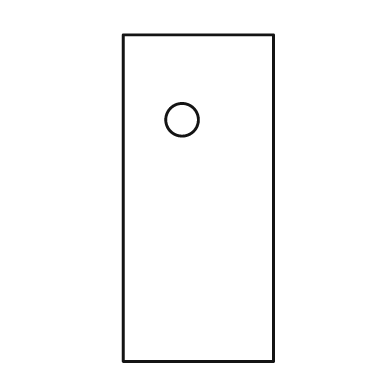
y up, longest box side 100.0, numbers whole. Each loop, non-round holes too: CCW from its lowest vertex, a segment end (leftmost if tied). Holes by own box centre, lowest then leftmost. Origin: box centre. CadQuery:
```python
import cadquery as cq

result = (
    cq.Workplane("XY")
    .moveTo(-23.0, -50.0)
    .lineTo(23.0, -50.0)
    .lineTo(23.0, 50.0)
    .lineTo(-23.0, 50.0)
    .close()
    .moveTo(-5.0, 24.0)
    .circle(5.0)
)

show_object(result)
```